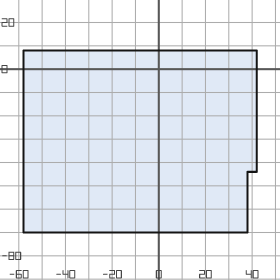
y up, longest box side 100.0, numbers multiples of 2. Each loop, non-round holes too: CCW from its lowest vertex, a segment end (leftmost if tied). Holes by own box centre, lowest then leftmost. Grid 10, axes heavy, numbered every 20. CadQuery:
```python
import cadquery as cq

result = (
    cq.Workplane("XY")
    .moveTo(-58.0, -70.0)
    .lineTo(38.0, -70.0)
    .lineTo(38.0, -44.0)
    .lineTo(42.0, -44.0)
    .lineTo(42.0, 8.0)
    .lineTo(-58.0, 8.0)
    .close()
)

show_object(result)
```